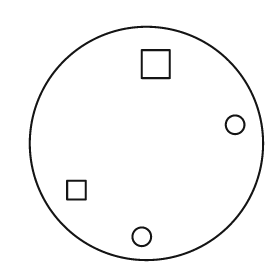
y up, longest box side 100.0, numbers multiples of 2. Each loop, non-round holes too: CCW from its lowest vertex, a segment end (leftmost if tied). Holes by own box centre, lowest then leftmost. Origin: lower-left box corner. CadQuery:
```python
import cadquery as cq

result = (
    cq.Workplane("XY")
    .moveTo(50.0, 50.0)
    .circle(50.0)
    .moveTo(48.0, 10.0)
    .circle(4.0)
    .moveTo(16.0, 26.0)
    .lineTo(24.0, 26.0)
    .lineTo(24.0, 34.0)
    .lineTo(16.0, 34.0)
    .close()
    .moveTo(88.0, 58.0)
    .circle(4.0)
    .moveTo(48.0, 78.0)
    .lineTo(60.0, 78.0)
    .lineTo(60.0, 90.0)
    .lineTo(48.0, 90.0)
    .close()
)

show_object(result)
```